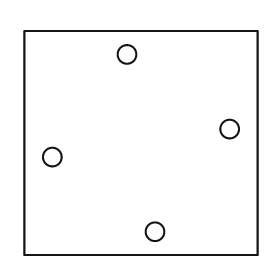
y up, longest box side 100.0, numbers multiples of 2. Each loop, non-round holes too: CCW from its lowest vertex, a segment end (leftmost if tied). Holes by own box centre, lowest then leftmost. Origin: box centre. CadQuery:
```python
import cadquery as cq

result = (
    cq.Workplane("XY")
    .moveTo(-50.0, -48.0)
    .lineTo(50.0, -48.0)
    .lineTo(50.0, 48.0)
    .lineTo(-50.0, 48.0)
    .close()
    .moveTo(6.0, -38.0)
    .circle(4.0)
    .moveTo(-38.0, -6.0)
    .circle(4.0)
    .moveTo(38.0, 6.0)
    .circle(4.0)
    .moveTo(-6.0, 38.0)
    .circle(4.0)
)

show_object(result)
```